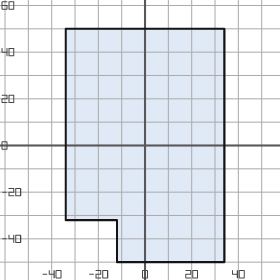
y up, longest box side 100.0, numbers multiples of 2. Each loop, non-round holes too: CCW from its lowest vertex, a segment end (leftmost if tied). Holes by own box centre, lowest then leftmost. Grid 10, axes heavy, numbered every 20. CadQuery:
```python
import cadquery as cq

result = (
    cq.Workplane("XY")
    .moveTo(-12.0, -50.0)
    .lineTo(34.0, -50.0)
    .lineTo(34.0, 50.0)
    .lineTo(-34.0, 50.0)
    .lineTo(-34.0, -32.0)
    .lineTo(-12.0, -32.0)
    .close()
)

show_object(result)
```